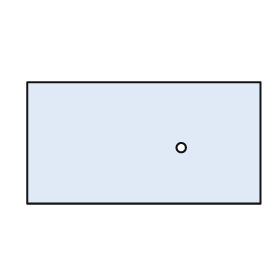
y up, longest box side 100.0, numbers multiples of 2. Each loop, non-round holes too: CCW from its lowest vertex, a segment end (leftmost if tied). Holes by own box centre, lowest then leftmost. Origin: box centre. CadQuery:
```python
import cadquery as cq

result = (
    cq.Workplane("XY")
    .moveTo(-50.0, -26.0)
    .lineTo(50.0, -26.0)
    .lineTo(50.0, 26.0)
    .lineTo(-50.0, 26.0)
    .close()
    .moveTo(16.0, -2.0)
    .circle(2.0)
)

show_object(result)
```